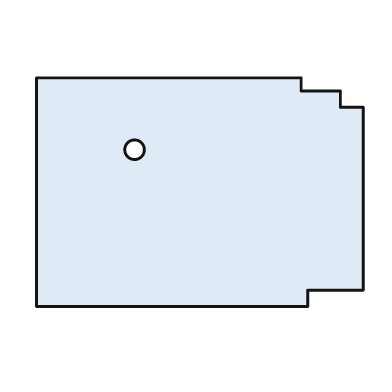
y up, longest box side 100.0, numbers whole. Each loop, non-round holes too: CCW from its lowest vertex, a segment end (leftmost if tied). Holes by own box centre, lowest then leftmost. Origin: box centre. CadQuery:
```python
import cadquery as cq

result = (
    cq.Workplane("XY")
    .moveTo(-50.0, -35.0)
    .lineTo(33.0, -35.0)
    .lineTo(33.0, -30.0)
    .lineTo(50.0, -30.0)
    .lineTo(50.0, 26.0)
    .lineTo(43.0, 26.0)
    .lineTo(43.0, 31.0)
    .lineTo(31.0, 31.0)
    .lineTo(31.0, 35.0)
    .lineTo(-50.0, 35.0)
    .close()
    .moveTo(-20.0, 13.0)
    .circle(3.0)
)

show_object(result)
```